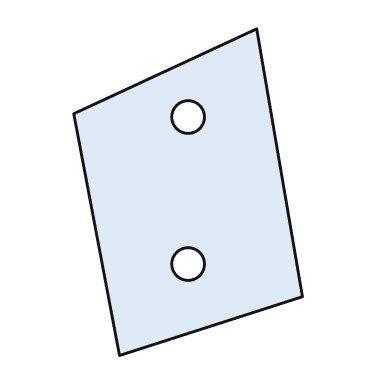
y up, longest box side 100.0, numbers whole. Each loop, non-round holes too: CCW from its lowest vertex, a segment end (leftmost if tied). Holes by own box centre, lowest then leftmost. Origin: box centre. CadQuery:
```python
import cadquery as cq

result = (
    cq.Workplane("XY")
    .moveTo(-21.0, -50.0)
    .lineTo(35.0, -32.0)
    .lineTo(21.0, 50.0)
    .lineTo(-35.0, 24.0)
    .close()
    .moveTo(0.0, -22.0)
    .circle(5.0)
    .moveTo(0.0, 23.0)
    .circle(5.0)
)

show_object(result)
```